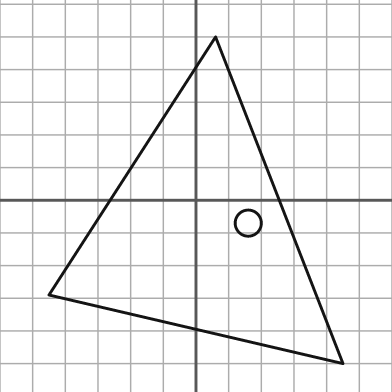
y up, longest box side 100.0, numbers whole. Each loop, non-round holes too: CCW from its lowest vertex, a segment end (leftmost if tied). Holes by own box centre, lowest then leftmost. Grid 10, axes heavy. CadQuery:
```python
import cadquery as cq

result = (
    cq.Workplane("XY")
    .moveTo(45.0, -50.0)
    .lineTo(6.0, 50.0)
    .lineTo(-45.0, -29.0)
    .close()
    .moveTo(16.0, -7.0)
    .circle(4.0)
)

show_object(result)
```